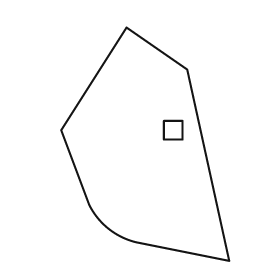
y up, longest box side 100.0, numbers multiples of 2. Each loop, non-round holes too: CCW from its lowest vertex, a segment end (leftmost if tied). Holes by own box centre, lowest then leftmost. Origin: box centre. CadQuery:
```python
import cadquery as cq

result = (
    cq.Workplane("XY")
    .moveTo(36.0, -50.0)
    .lineTo(18.0, 32.0)
    .lineTo(-8.0, 50.0)
    .lineTo(-36.0, 6.0)
    .lineTo(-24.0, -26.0)
    .threePointArc((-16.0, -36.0), (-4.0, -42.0))
    .close()
    .moveTo(8.0, 2.0)
    .lineTo(16.0, 2.0)
    .lineTo(16.0, 10.0)
    .lineTo(8.0, 10.0)
    .close()
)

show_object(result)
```